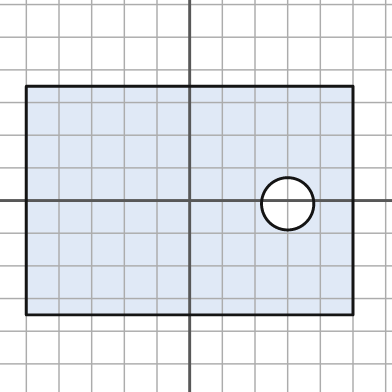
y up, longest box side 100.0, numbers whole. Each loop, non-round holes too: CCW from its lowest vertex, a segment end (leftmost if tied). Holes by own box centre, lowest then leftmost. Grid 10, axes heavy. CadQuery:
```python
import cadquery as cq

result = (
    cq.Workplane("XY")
    .moveTo(-50.0, -35.0)
    .lineTo(50.0, -35.0)
    .lineTo(50.0, 35.0)
    .lineTo(-50.0, 35.0)
    .close()
    .moveTo(30.0, -1.0)
    .circle(8.0)
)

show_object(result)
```